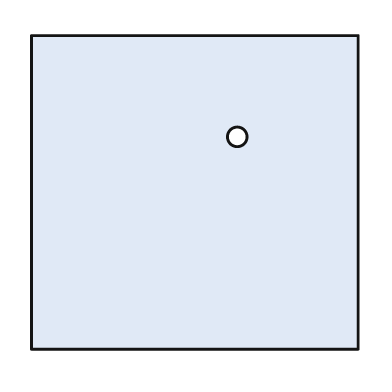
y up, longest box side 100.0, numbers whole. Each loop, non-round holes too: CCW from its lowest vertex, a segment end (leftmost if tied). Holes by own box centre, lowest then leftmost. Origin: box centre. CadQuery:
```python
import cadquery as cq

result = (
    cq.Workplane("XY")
    .moveTo(-50.0, -48.0)
    .lineTo(50.0, -48.0)
    .lineTo(50.0, 48.0)
    .lineTo(-50.0, 48.0)
    .close()
    .moveTo(13.0, 17.0)
    .circle(3.0)
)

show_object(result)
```